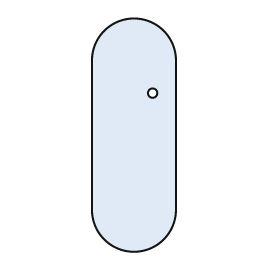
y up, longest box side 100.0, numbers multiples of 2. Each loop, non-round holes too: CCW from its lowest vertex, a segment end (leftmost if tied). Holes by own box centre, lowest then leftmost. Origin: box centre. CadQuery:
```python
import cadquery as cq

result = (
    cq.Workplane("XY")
    .moveTo(-18.0, -32.0)
    .threePointArc((0.0, -50.0), (18.0, -32.0))
    .lineTo(18.0, 32.0)
    .threePointArc((0.0, 50.0), (-18.0, 32.0))
    .close()
    .moveTo(8.0, 18.0)
    .circle(2.0)
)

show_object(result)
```